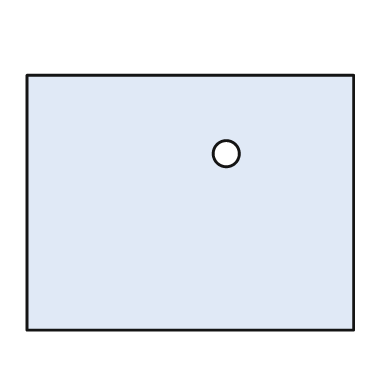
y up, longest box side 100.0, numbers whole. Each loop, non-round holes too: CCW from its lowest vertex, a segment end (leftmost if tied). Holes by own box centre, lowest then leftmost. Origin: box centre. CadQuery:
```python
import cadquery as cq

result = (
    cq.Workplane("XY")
    .moveTo(-50.0, -39.0)
    .lineTo(50.0, -39.0)
    .lineTo(50.0, 39.0)
    .lineTo(-50.0, 39.0)
    .close()
    .moveTo(11.0, 15.0)
    .circle(4.0)
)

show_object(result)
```